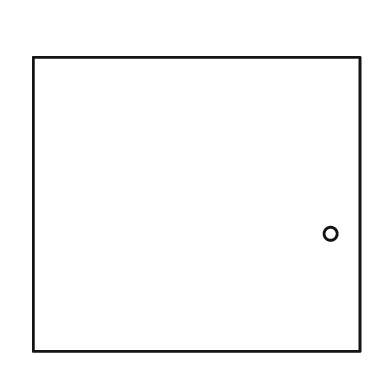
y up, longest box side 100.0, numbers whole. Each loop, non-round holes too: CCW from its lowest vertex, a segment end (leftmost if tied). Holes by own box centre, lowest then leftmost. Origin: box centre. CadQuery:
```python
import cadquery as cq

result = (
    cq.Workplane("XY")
    .moveTo(-50.0, -45.0)
    .lineTo(50.0, -45.0)
    .lineTo(50.0, 45.0)
    .lineTo(-50.0, 45.0)
    .close()
    .moveTo(41.0, -9.0)
    .circle(2.0)
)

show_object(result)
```